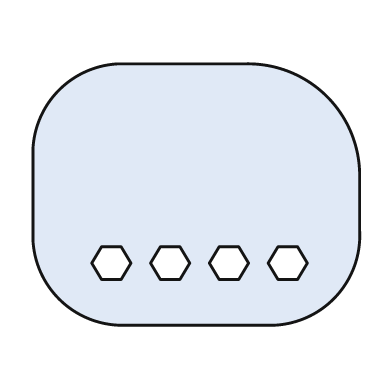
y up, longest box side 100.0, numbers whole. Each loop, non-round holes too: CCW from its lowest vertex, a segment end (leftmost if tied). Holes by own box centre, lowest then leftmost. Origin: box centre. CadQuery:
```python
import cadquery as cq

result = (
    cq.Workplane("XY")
    .moveTo(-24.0, -40.0)
    .lineTo(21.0, -40.0)
    .threePointArc((42.0, -32.0), (50.0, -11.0))
    .lineTo(50.0, 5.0)
    .threePointArc((40.0, 30.0), (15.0, 40.0))
    .lineTo(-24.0, 40.0)
    .threePointArc((-42.0, 32.0), (-50.0, 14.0))
    .lineTo(-50.0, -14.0)
    .threePointArc((-42.0, -32.0), (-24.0, -40.0))
    .close()
    .moveTo(-29.0, -26.0)
    .lineTo(-23.0, -26.0)
    .lineTo(-20.0, -21.0)
    .lineTo(-23.0, -16.0)
    .lineTo(-29.0, -16.0)
    .lineTo(-32.0, -21.0)
    .close()
    .moveTo(-11.0, -26.0)
    .lineTo(-5.0, -26.0)
    .lineTo(-2.0, -21.0)
    .lineTo(-5.0, -16.0)
    .lineTo(-11.0, -16.0)
    .lineTo(-14.0, -21.0)
    .close()
    .moveTo(7.0, -26.0)
    .lineTo(13.0, -26.0)
    .lineTo(16.0, -21.0)
    .lineTo(13.0, -16.0)
    .lineTo(7.0, -16.0)
    .lineTo(4.0, -21.0)
    .close()
    .moveTo(25.0, -26.0)
    .lineTo(31.0, -26.0)
    .lineTo(34.0, -21.0)
    .lineTo(31.0, -16.0)
    .lineTo(25.0, -16.0)
    .lineTo(22.0, -21.0)
    .close()
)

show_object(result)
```